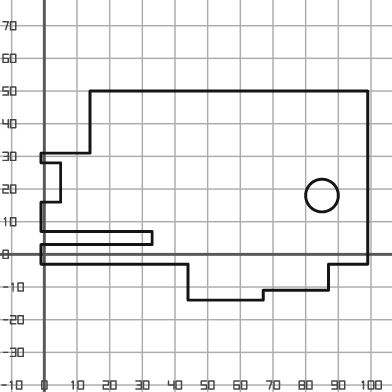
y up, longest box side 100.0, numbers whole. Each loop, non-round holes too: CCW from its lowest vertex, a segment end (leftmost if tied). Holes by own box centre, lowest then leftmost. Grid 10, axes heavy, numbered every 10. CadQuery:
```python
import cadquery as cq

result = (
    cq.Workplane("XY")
    .moveTo(44.0, -14.0)
    .lineTo(67.0, -14.0)
    .lineTo(67.0, -11.0)
    .lineTo(87.0, -11.0)
    .lineTo(87.0, -3.0)
    .lineTo(99.0, -3.0)
    .lineTo(99.0, 50.0)
    .lineTo(14.0, 50.0)
    .lineTo(14.0, 31.0)
    .lineTo(-1.0, 31.0)
    .lineTo(-1.0, 28.0)
    .lineTo(5.0, 28.0)
    .lineTo(5.0, 16.0)
    .lineTo(-1.0, 16.0)
    .lineTo(-1.0, 7.0)
    .lineTo(33.0, 7.0)
    .lineTo(33.0, 3.0)
    .lineTo(-1.0, 3.0)
    .lineTo(-1.0, -3.0)
    .lineTo(44.0, -3.0)
    .close()
    .moveTo(85.0, 18.0)
    .circle(5.0)
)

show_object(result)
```